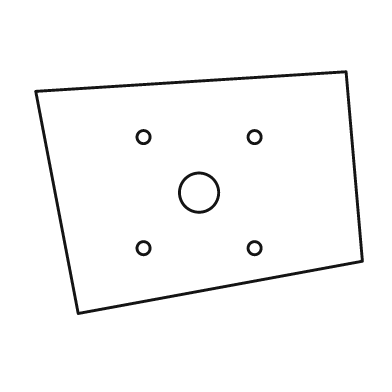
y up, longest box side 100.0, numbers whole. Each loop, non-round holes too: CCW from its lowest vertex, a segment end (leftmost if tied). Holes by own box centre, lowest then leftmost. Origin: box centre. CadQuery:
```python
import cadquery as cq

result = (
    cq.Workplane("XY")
    .moveTo(-37.0, -37.0)
    .lineTo(50.0, -21.0)
    .lineTo(45.0, 37.0)
    .lineTo(-50.0, 31.0)
    .close()
    .moveTo(-17.0, -17.0)
    .circle(2.0)
    .moveTo(17.0, -17.0)
    .circle(2.0)
    .moveTo(0.0, 0.0)
    .circle(6.0)
    .moveTo(-17.0, 17.0)
    .circle(2.0)
    .moveTo(17.0, 17.0)
    .circle(2.0)
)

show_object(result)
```